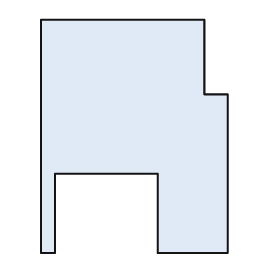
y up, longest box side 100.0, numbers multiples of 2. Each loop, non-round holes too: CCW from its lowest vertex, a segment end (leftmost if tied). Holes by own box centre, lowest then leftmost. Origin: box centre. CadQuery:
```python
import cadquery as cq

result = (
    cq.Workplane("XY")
    .moveTo(-40.0, -50.0)
    .lineTo(-34.0, -50.0)
    .lineTo(-34.0, -16.0)
    .lineTo(10.0, -16.0)
    .lineTo(10.0, -50.0)
    .lineTo(40.0, -50.0)
    .lineTo(40.0, 18.0)
    .lineTo(30.0, 18.0)
    .lineTo(30.0, 50.0)
    .lineTo(-40.0, 50.0)
    .close()
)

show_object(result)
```